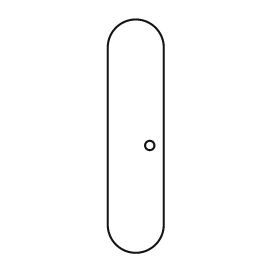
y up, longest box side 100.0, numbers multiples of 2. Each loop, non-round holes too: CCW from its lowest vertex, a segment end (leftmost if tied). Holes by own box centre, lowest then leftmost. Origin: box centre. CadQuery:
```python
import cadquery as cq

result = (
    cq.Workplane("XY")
    .moveTo(-12.0, -38.0)
    .threePointArc((0.0, -50.0), (12.0, -38.0))
    .lineTo(12.0, 38.0)
    .threePointArc((0.0, 50.0), (-12.0, 38.0))
    .close()
    .moveTo(6.0, -4.0)
    .circle(2.0)
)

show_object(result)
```